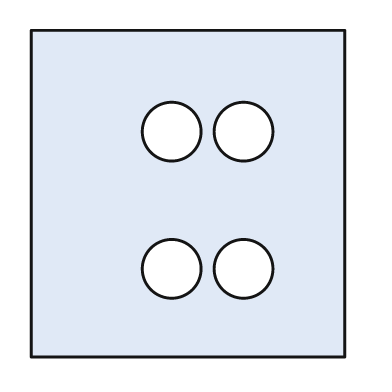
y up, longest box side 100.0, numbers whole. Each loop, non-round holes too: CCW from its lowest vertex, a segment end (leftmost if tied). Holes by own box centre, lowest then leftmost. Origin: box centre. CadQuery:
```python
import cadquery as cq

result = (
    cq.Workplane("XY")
    .moveTo(-48.0, -50.0)
    .lineTo(48.0, -50.0)
    .lineTo(48.0, 50.0)
    .lineTo(-48.0, 50.0)
    .close()
    .moveTo(-5.0, -23.0)
    .circle(9.0)
    .moveTo(17.0, -23.0)
    .circle(9.0)
    .moveTo(-5.0, 19.0)
    .circle(9.0)
    .moveTo(17.0, 19.0)
    .circle(9.0)
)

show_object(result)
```